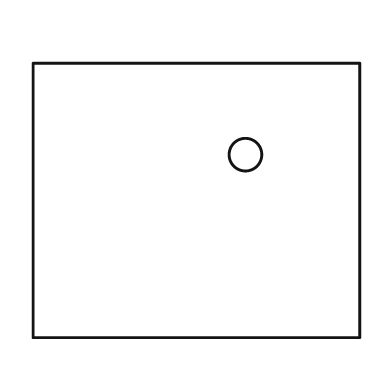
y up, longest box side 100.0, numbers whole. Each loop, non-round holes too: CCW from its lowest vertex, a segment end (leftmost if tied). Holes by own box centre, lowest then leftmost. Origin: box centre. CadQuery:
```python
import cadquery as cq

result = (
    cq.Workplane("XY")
    .moveTo(-50.0, -42.0)
    .lineTo(50.0, -42.0)
    .lineTo(50.0, 42.0)
    .lineTo(-50.0, 42.0)
    .close()
    .moveTo(15.0, 14.0)
    .circle(5.0)
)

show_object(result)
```